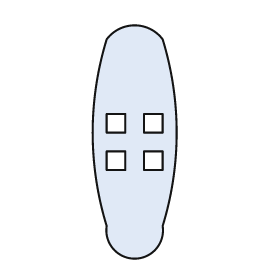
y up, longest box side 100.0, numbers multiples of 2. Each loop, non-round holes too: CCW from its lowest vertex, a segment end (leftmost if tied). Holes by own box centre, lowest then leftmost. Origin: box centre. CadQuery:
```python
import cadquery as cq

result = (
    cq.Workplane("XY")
    .moveTo(-12.0, -36.0)
    .threePointArc((0.0, -50.0), (12.0, -36.0))
    .threePointArc((18.0, 4.0), (12.0, 44.0))
    .threePointArc((0.0, 50.0), (-12.0, 44.0))
    .threePointArc((-18.0, 4.0), (-12.0, -36.0))
    .close()
    .moveTo(-12.0, -12.0)
    .lineTo(-4.0, -12.0)
    .lineTo(-4.0, -4.0)
    .lineTo(-12.0, -4.0)
    .close()
    .moveTo(4.0, -12.0)
    .lineTo(12.0, -12.0)
    .lineTo(12.0, -4.0)
    .lineTo(4.0, -4.0)
    .close()
    .moveTo(-12.0, 4.0)
    .lineTo(-4.0, 4.0)
    .lineTo(-4.0, 12.0)
    .lineTo(-12.0, 12.0)
    .close()
    .moveTo(4.0, 4.0)
    .lineTo(12.0, 4.0)
    .lineTo(12.0, 12.0)
    .lineTo(4.0, 12.0)
    .close()
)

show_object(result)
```